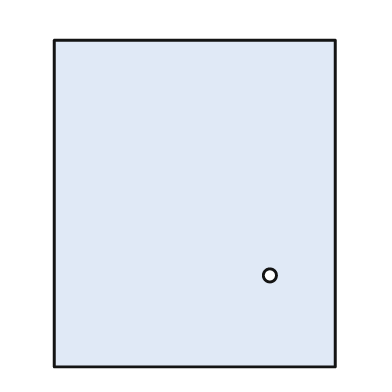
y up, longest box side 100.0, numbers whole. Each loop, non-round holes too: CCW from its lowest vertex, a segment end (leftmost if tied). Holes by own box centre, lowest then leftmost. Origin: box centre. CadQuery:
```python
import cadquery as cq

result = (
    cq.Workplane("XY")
    .moveTo(-43.0, -50.0)
    .lineTo(43.0, -50.0)
    .lineTo(43.0, 50.0)
    .lineTo(-43.0, 50.0)
    .close()
    .moveTo(23.0, -22.0)
    .circle(2.0)
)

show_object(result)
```